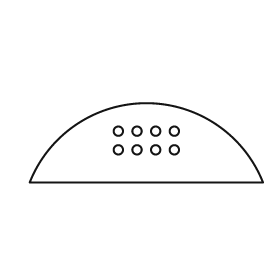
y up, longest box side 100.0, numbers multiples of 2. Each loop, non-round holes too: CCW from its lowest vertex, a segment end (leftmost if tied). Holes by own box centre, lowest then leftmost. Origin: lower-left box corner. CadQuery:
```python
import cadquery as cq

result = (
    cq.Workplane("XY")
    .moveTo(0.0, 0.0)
    .lineTo(100.0, 0.0)
    .threePointArc((50.0, 34.0), (0.0, 0.0))
    .close()
    .moveTo(38.0, 14.0)
    .circle(2.0)
    .moveTo(46.0, 14.0)
    .circle(2.0)
    .moveTo(54.0, 14.0)
    .circle(2.0)
    .moveTo(62.0, 14.0)
    .circle(2.0)
    .moveTo(38.0, 22.0)
    .circle(2.0)
    .moveTo(46.0, 22.0)
    .circle(2.0)
    .moveTo(54.0, 22.0)
    .circle(2.0)
    .moveTo(62.0, 22.0)
    .circle(2.0)
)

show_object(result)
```